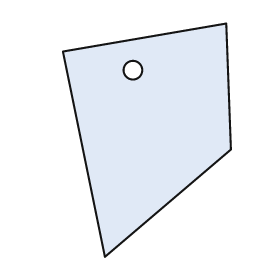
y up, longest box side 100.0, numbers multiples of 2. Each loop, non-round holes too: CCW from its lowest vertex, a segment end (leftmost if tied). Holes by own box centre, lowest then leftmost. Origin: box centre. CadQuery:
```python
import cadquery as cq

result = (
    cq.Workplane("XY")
    .moveTo(-18.0, -50.0)
    .lineTo(36.0, -4.0)
    .lineTo(34.0, 50.0)
    .lineTo(-36.0, 38.0)
    .close()
    .moveTo(-6.0, 30.0)
    .circle(4.0)
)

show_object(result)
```